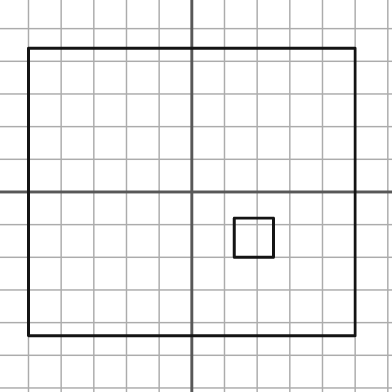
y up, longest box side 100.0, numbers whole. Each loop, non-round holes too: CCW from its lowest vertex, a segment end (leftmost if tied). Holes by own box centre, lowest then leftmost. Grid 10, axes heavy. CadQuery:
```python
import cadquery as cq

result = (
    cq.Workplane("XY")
    .moveTo(-50.0, -44.0)
    .lineTo(50.0, -44.0)
    .lineTo(50.0, 44.0)
    .lineTo(-50.0, 44.0)
    .close()
    .moveTo(13.0, -20.0)
    .lineTo(25.0, -20.0)
    .lineTo(25.0, -8.0)
    .lineTo(13.0, -8.0)
    .close()
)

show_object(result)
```